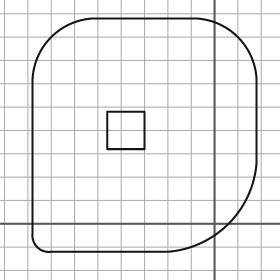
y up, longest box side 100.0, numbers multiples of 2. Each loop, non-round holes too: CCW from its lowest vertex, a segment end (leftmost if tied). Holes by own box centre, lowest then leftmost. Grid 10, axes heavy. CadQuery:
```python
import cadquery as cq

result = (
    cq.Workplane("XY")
    .moveTo(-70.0, -12.0)
    .lineTo(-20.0, -12.0)
    .threePointArc((6.0, 0.0), (18.0, 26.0))
    .lineTo(18.0, 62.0)
    .threePointArc((10.0, 80.0), (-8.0, 88.0))
    .lineTo(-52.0, 88.0)
    .threePointArc((-70.0, 80.0), (-78.0, 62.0))
    .lineTo(-78.0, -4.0)
    .threePointArc((-76.0, -10.0), (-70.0, -12.0))
    .close()
    .moveTo(-46.0, 32.0)
    .lineTo(-30.0, 32.0)
    .lineTo(-30.0, 48.0)
    .lineTo(-46.0, 48.0)
    .close()
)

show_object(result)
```